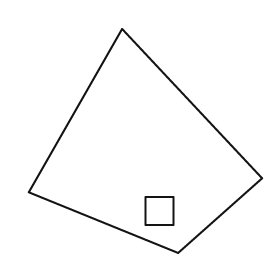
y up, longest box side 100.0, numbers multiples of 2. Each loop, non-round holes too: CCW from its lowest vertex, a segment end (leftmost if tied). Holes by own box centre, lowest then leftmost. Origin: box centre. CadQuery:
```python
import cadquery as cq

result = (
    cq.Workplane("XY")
    .moveTo(14.0, -48.0)
    .lineTo(50.0, -16.0)
    .lineTo(-10.0, 48.0)
    .lineTo(-50.0, -22.0)
    .close()
    .moveTo(0.0, -36.0)
    .lineTo(12.0, -36.0)
    .lineTo(12.0, -24.0)
    .lineTo(0.0, -24.0)
    .close()
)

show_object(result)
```